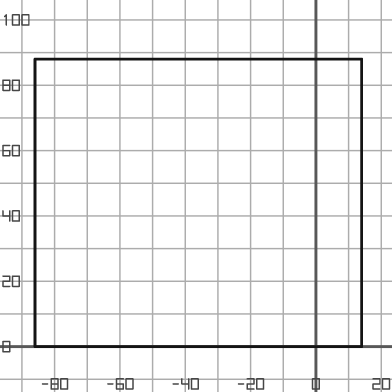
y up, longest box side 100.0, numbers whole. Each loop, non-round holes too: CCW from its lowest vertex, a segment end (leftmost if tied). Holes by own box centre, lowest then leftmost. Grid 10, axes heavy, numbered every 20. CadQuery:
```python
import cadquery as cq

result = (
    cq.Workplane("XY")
    .moveTo(-86.0, 0.0)
    .lineTo(14.0, 0.0)
    .lineTo(14.0, 88.0)
    .lineTo(-86.0, 88.0)
    .close()
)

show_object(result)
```